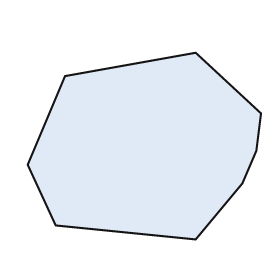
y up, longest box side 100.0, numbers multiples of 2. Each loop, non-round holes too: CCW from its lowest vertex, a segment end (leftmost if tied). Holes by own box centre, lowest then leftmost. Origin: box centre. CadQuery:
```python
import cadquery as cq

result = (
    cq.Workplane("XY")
    .moveTo(22.0, -40.0)
    .lineTo(42.0, -16.0)
    .lineTo(48.0, -2.0)
    .lineTo(50.0, 14.0)
    .lineTo(22.0, 40.0)
    .lineTo(-34.0, 30.0)
    .lineTo(-50.0, -8.0)
    .lineTo(-38.0, -34.0)
    .close()
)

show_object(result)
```